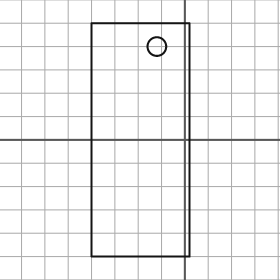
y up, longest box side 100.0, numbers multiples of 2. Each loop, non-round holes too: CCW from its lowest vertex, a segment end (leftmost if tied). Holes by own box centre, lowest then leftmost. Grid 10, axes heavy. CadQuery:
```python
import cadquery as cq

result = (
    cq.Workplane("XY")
    .moveTo(-40.0, -50.0)
    .lineTo(2.0, -50.0)
    .lineTo(2.0, 50.0)
    .lineTo(-40.0, 50.0)
    .close()
    .moveTo(-12.0, 40.0)
    .circle(4.0)
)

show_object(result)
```